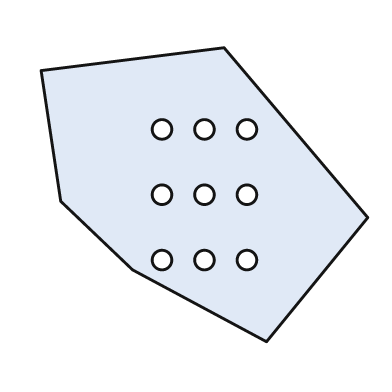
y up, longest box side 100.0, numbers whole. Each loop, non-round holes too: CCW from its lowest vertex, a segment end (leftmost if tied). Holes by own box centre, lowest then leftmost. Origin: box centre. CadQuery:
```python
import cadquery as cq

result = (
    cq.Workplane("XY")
    .moveTo(19.0, -45.0)
    .lineTo(50.0, -7.0)
    .lineTo(6.0, 45.0)
    .lineTo(-50.0, 38.0)
    .lineTo(-44.0, -2.0)
    .lineTo(-22.0, -23.0)
    .close()
    .moveTo(-13.0, -20.0)
    .circle(3.0)
    .moveTo(0.0, -20.0)
    .circle(3.0)
    .moveTo(13.0, -20.0)
    .circle(3.0)
    .moveTo(-13.0, 0.0)
    .circle(3.0)
    .moveTo(0.0, 0.0)
    .circle(3.0)
    .moveTo(13.0, 0.0)
    .circle(3.0)
    .moveTo(-13.0, 20.0)
    .circle(3.0)
    .moveTo(0.0, 20.0)
    .circle(3.0)
    .moveTo(13.0, 20.0)
    .circle(3.0)
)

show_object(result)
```